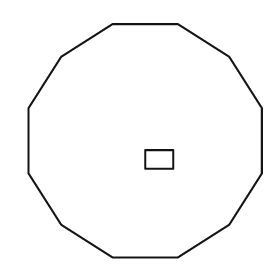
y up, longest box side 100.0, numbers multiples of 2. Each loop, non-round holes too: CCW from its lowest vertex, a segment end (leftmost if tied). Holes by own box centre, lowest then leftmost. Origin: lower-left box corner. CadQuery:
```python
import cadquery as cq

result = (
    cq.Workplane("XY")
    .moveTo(36.0, 0.0)
    .lineTo(64.0, 0.0)
    .lineTo(86.0, 14.0)
    .lineTo(100.0, 36.0)
    .lineTo(100.0, 64.0)
    .lineTo(86.0, 86.0)
    .lineTo(64.0, 100.0)
    .lineTo(36.0, 100.0)
    .lineTo(14.0, 86.0)
    .lineTo(0.0, 64.0)
    .lineTo(0.0, 36.0)
    .lineTo(14.0, 14.0)
    .close()
    .moveTo(50.0, 38.0)
    .lineTo(62.0, 38.0)
    .lineTo(62.0, 46.0)
    .lineTo(50.0, 46.0)
    .close()
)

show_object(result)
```